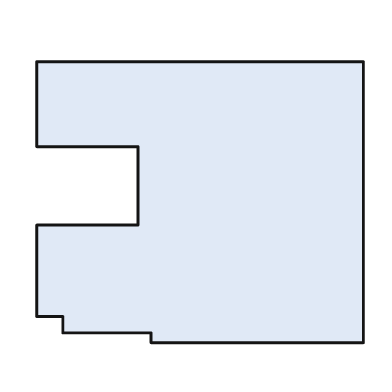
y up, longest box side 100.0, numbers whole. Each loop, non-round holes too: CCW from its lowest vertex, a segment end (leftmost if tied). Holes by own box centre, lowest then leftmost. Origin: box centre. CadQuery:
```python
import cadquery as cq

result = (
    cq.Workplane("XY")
    .moveTo(-15.0, -43.0)
    .lineTo(50.0, -43.0)
    .lineTo(50.0, 43.0)
    .lineTo(-50.0, 43.0)
    .lineTo(-50.0, 17.0)
    .lineTo(-19.0, 17.0)
    .lineTo(-19.0, -7.0)
    .lineTo(-50.0, -7.0)
    .lineTo(-50.0, -35.0)
    .lineTo(-42.0, -35.0)
    .lineTo(-42.0, -40.0)
    .lineTo(-15.0, -40.0)
    .close()
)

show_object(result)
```